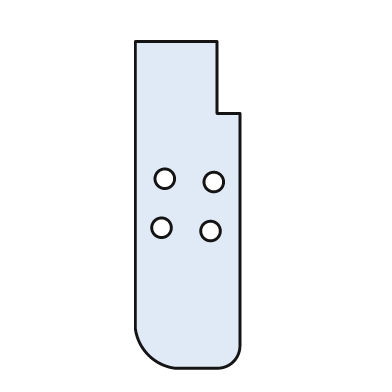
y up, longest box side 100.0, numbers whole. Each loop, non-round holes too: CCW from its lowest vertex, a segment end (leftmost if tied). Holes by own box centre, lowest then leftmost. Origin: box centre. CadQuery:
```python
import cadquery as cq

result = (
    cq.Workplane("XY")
    .moveTo(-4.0, -50.0)
    .lineTo(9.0, -50.0)
    .threePointArc((14.0, -48.0), (16.0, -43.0))
    .lineTo(16.0, 28.0)
    .lineTo(9.0, 28.0)
    .lineTo(9.0, 50.0)
    .lineTo(-16.0, 50.0)
    .lineTo(-16.0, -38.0)
    .threePointArc((-12.0, -46.0), (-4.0, -50.0))
    .close()
    .moveTo(7.0, -8.0)
    .circle(3.0)
    .moveTo(-8.0, -7.0)
    .circle(3.0)
    .moveTo(8.0, 7.0)
    .circle(3.0)
    .moveTo(-7.0, 8.0)
    .circle(3.0)
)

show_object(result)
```